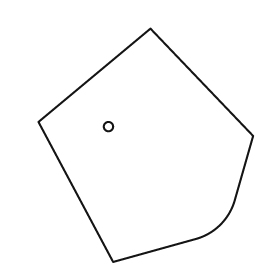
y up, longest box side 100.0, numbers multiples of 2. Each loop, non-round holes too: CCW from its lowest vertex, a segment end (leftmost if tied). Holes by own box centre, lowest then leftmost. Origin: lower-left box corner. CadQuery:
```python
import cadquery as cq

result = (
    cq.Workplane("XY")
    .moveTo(32.0, 0.0)
    .lineTo(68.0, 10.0)
    .threePointArc((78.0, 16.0), (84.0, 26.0))
    .lineTo(92.0, 54.0)
    .lineTo(48.0, 100.0)
    .lineTo(0.0, 60.0)
    .close()
    .moveTo(30.0, 58.0)
    .circle(2.0)
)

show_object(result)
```